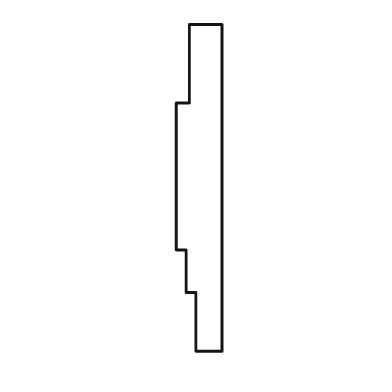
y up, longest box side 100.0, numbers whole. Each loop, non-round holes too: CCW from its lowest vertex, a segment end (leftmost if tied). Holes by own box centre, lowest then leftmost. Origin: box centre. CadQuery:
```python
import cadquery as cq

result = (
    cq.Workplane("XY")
    .moveTo(-1.0, -50.0)
    .lineTo(7.0, -50.0)
    .lineTo(7.0, 50.0)
    .lineTo(-3.0, 50.0)
    .lineTo(-3.0, 26.0)
    .lineTo(-7.0, 26.0)
    .lineTo(-7.0, -19.0)
    .lineTo(-4.0, -19.0)
    .lineTo(-4.0, -32.0)
    .lineTo(-1.0, -32.0)
    .close()
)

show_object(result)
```